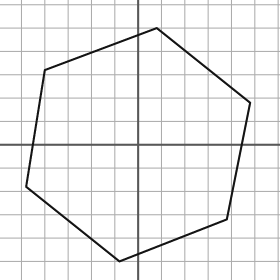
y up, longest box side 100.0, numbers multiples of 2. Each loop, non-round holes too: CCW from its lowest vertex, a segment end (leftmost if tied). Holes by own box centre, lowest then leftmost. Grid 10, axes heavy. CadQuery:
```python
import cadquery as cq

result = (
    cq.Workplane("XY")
    .moveTo(-8.0, -50.0)
    .lineTo(38.0, -32.0)
    .lineTo(48.0, 18.0)
    .lineTo(8.0, 50.0)
    .lineTo(-40.0, 32.0)
    .lineTo(-48.0, -18.0)
    .close()
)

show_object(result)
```